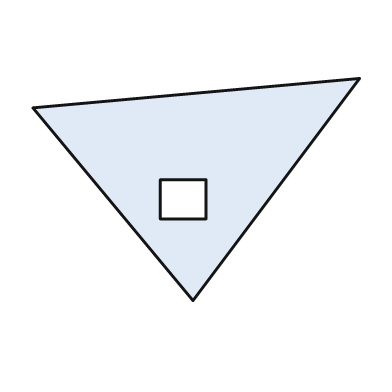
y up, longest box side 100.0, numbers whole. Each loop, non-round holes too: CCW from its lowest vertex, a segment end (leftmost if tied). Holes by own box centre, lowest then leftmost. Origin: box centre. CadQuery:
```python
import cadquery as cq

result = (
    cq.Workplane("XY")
    .moveTo(-1.0, -34.0)
    .lineTo(50.0, 34.0)
    .lineTo(-50.0, 25.0)
    .close()
    .moveTo(-11.0, -9.0)
    .lineTo(3.0, -9.0)
    .lineTo(3.0, 3.0)
    .lineTo(-11.0, 3.0)
    .close()
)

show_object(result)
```